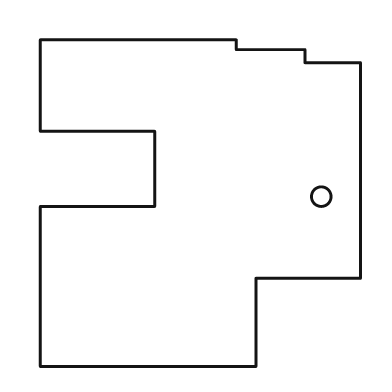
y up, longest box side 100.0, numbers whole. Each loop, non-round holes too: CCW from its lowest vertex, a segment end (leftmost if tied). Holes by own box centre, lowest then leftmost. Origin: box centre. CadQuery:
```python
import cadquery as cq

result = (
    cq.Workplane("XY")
    .moveTo(-49.0, -50.0)
    .lineTo(17.0, -50.0)
    .lineTo(17.0, -23.0)
    .lineTo(49.0, -23.0)
    .lineTo(49.0, 43.0)
    .lineTo(32.0, 43.0)
    .lineTo(32.0, 47.0)
    .lineTo(11.0, 47.0)
    .lineTo(11.0, 50.0)
    .lineTo(-49.0, 50.0)
    .lineTo(-49.0, 22.0)
    .lineTo(-14.0, 22.0)
    .lineTo(-14.0, -1.0)
    .lineTo(-49.0, -1.0)
    .close()
    .moveTo(37.0, 2.0)
    .circle(3.0)
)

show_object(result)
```